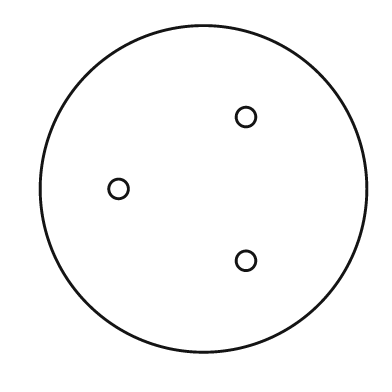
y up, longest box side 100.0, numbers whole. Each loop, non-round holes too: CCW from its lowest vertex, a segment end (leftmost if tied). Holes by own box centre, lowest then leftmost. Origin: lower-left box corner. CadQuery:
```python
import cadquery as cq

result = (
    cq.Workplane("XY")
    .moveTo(50.0, 50.0)
    .circle(50.0)
    .moveTo(63.0, 28.0)
    .circle(3.0)
    .moveTo(24.0, 50.0)
    .circle(3.0)
    .moveTo(63.0, 72.0)
    .circle(3.0)
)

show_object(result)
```